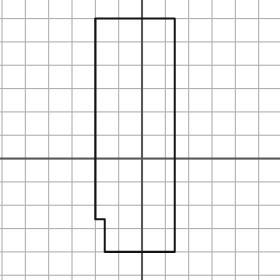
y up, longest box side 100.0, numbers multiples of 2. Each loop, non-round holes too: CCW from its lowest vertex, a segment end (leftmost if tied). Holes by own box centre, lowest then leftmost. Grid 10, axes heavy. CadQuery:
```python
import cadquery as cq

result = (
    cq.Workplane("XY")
    .moveTo(-16.0, -40.0)
    .lineTo(14.0, -40.0)
    .lineTo(14.0, 60.0)
    .lineTo(-20.0, 60.0)
    .lineTo(-20.0, -26.0)
    .lineTo(-16.0, -26.0)
    .close()
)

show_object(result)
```